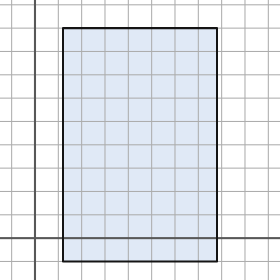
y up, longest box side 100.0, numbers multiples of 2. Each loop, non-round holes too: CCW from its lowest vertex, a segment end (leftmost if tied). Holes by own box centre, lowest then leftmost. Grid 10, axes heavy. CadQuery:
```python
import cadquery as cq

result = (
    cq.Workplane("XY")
    .moveTo(12.0, -10.0)
    .lineTo(78.0, -10.0)
    .lineTo(78.0, 90.0)
    .lineTo(12.0, 90.0)
    .close()
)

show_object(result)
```